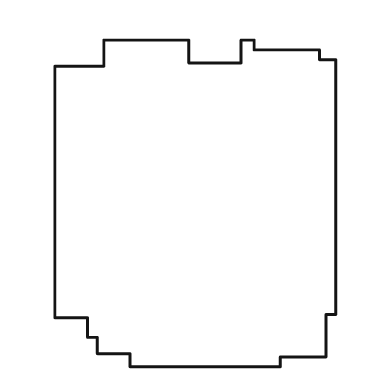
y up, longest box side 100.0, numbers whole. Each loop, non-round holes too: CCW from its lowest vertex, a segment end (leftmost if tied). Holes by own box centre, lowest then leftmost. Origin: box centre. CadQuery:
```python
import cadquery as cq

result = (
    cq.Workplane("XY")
    .moveTo(-20.0, -50.0)
    .lineTo(26.0, -50.0)
    .lineTo(26.0, -47.0)
    .lineTo(40.0, -47.0)
    .lineTo(40.0, -34.0)
    .lineTo(43.0, -34.0)
    .lineTo(43.0, 44.0)
    .lineTo(38.0, 44.0)
    .lineTo(38.0, 47.0)
    .lineTo(18.0, 47.0)
    .lineTo(18.0, 50.0)
    .lineTo(14.0, 50.0)
    .lineTo(14.0, 43.0)
    .lineTo(-2.0, 43.0)
    .lineTo(-2.0, 50.0)
    .lineTo(-28.0, 50.0)
    .lineTo(-28.0, 42.0)
    .lineTo(-43.0, 42.0)
    .lineTo(-43.0, -35.0)
    .lineTo(-33.0, -35.0)
    .lineTo(-33.0, -41.0)
    .lineTo(-30.0, -41.0)
    .lineTo(-30.0, -46.0)
    .lineTo(-20.0, -46.0)
    .close()
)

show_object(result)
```